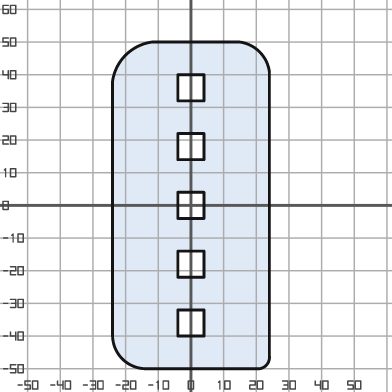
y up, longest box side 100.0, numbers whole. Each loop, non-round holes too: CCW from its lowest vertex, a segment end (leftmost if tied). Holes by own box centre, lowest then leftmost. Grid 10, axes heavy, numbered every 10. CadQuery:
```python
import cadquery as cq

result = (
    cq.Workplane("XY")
    .moveTo(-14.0, -50.0)
    .lineTo(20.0, -50.0)
    .threePointArc((23.0, -49.0), (24.0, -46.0))
    .lineTo(24.0, 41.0)
    .threePointArc((21.0, 47.0), (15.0, 50.0))
    .lineTo(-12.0, 50.0)
    .threePointArc((-20.0, 46.0), (-24.0, 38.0))
    .lineTo(-24.0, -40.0)
    .threePointArc((-21.0, -47.0), (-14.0, -50.0))
    .close()
    .moveTo(-4.0, -40.0)
    .lineTo(4.0, -40.0)
    .lineTo(4.0, -32.0)
    .lineTo(-4.0, -32.0)
    .close()
    .moveTo(-4.0, -22.0)
    .lineTo(4.0, -22.0)
    .lineTo(4.0, -14.0)
    .lineTo(-4.0, -14.0)
    .close()
    .moveTo(-4.0, -4.0)
    .lineTo(4.0, -4.0)
    .lineTo(4.0, 4.0)
    .lineTo(-4.0, 4.0)
    .close()
    .moveTo(-4.0, 14.0)
    .lineTo(4.0, 14.0)
    .lineTo(4.0, 22.0)
    .lineTo(-4.0, 22.0)
    .close()
    .moveTo(-4.0, 32.0)
    .lineTo(4.0, 32.0)
    .lineTo(4.0, 40.0)
    .lineTo(-4.0, 40.0)
    .close()
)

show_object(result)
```